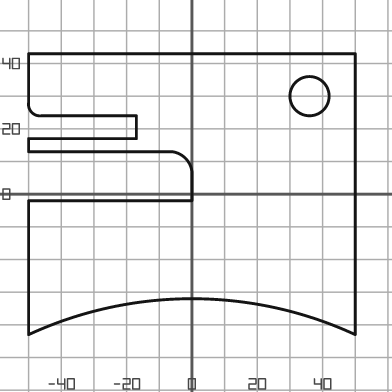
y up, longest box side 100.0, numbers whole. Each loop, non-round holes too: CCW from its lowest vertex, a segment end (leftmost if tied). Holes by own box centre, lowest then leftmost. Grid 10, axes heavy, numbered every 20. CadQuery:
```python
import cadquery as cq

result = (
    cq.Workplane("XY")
    .moveTo(-50.0, -43.0)
    .threePointArc((0.0, -32.0), (50.0, -43.0))
    .lineTo(50.0, 43.0)
    .lineTo(-50.0, 43.0)
    .lineTo(-50.0, 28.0)
    .threePointArc((-49.0, 25.0), (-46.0, 24.0))
    .lineTo(-17.0, 24.0)
    .lineTo(-17.0, 17.0)
    .lineTo(-50.0, 17.0)
    .lineTo(-50.0, 13.0)
    .lineTo(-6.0, 13.0)
    .threePointArc((-2.0, 11.0), (0.0, 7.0))
    .lineTo(0.0, -2.0)
    .lineTo(-50.0, -2.0)
    .close()
    .moveTo(36.0, 30.0)
    .circle(6.0)
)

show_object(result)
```